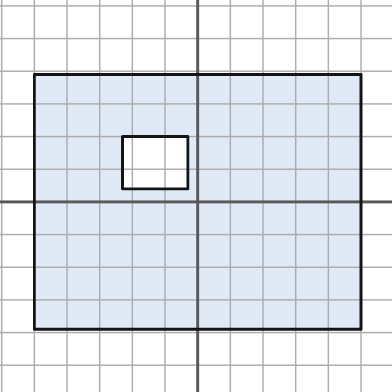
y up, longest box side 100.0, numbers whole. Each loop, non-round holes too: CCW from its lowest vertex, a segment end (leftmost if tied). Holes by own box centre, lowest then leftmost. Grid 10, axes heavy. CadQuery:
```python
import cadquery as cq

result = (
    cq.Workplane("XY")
    .moveTo(-50.0, -39.0)
    .lineTo(50.0, -39.0)
    .lineTo(50.0, 39.0)
    .lineTo(-50.0, 39.0)
    .close()
    .moveTo(-23.0, 4.0)
    .lineTo(-3.0, 4.0)
    .lineTo(-3.0, 20.0)
    .lineTo(-23.0, 20.0)
    .close()
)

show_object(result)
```